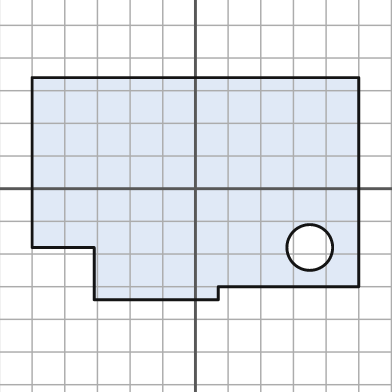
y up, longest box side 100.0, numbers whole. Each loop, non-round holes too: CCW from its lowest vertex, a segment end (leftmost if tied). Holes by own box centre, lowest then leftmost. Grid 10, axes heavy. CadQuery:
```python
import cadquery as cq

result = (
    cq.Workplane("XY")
    .moveTo(-31.0, -34.0)
    .lineTo(7.0, -34.0)
    .lineTo(7.0, -30.0)
    .lineTo(50.0, -30.0)
    .lineTo(50.0, 34.0)
    .lineTo(-50.0, 34.0)
    .lineTo(-50.0, -18.0)
    .lineTo(-31.0, -18.0)
    .close()
    .moveTo(35.0, -18.0)
    .circle(7.0)
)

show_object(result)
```